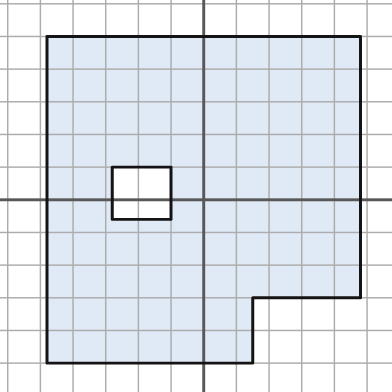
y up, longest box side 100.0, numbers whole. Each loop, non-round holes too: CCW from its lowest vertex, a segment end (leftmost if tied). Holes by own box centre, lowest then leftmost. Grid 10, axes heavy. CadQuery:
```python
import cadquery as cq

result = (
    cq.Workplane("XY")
    .moveTo(-48.0, -50.0)
    .lineTo(15.0, -50.0)
    .lineTo(15.0, -30.0)
    .lineTo(48.0, -30.0)
    .lineTo(48.0, 50.0)
    .lineTo(-48.0, 50.0)
    .close()
    .moveTo(-28.0, -6.0)
    .lineTo(-10.0, -6.0)
    .lineTo(-10.0, 10.0)
    .lineTo(-28.0, 10.0)
    .close()
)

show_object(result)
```